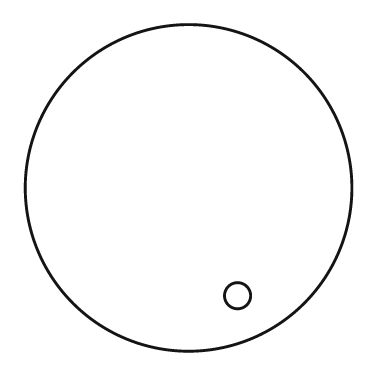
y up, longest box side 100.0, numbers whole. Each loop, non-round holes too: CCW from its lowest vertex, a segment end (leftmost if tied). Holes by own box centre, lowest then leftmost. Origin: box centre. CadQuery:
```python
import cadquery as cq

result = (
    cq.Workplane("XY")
    .moveTo(0.0, 0.0)
    .circle(50.0)
    .moveTo(15.0, -33.0)
    .circle(4.0)
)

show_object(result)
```